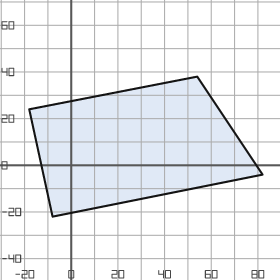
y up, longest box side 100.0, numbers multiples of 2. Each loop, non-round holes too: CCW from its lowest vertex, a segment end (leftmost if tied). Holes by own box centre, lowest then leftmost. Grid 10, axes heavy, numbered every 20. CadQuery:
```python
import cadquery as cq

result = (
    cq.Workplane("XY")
    .moveTo(-8.0, -22.0)
    .lineTo(82.0, -4.0)
    .lineTo(54.0, 38.0)
    .lineTo(-18.0, 24.0)
    .close()
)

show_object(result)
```